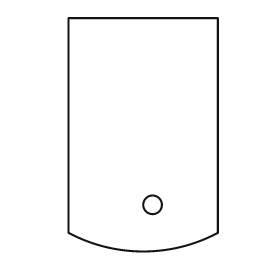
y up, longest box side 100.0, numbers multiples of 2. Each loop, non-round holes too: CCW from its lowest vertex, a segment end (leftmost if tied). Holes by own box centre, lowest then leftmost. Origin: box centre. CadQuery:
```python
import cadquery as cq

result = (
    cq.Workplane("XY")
    .moveTo(-32.0, -42.0)
    .threePointArc((0.0, -50.0), (32.0, -42.0))
    .lineTo(32.0, 50.0)
    .lineTo(-32.0, 50.0)
    .close()
    .moveTo(4.0, -30.0)
    .circle(4.0)
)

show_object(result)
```